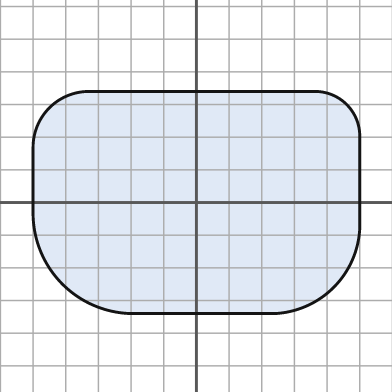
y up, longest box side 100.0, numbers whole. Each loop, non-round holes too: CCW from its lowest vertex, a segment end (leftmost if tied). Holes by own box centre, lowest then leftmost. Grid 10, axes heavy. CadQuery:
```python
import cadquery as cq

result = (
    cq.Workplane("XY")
    .moveTo(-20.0, -34.0)
    .lineTo(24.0, -34.0)
    .threePointArc((42.0, -26.0), (50.0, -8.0))
    .lineTo(50.0, 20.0)
    .threePointArc((46.0, 30.0), (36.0, 34.0))
    .lineTo(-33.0, 34.0)
    .threePointArc((-45.0, 29.0), (-50.0, 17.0))
    .lineTo(-50.0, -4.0)
    .threePointArc((-41.0, -25.0), (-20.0, -34.0))
    .close()
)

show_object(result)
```